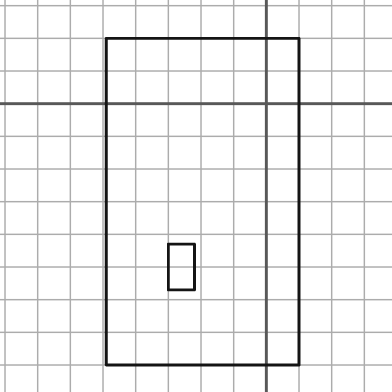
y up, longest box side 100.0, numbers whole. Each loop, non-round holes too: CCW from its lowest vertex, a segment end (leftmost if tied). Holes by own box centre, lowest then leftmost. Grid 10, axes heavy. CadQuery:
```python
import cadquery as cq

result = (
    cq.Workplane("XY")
    .moveTo(-49.0, -80.0)
    .lineTo(10.0, -80.0)
    .lineTo(10.0, 20.0)
    .lineTo(-49.0, 20.0)
    .close()
    .moveTo(-30.0, -57.0)
    .lineTo(-22.0, -57.0)
    .lineTo(-22.0, -43.0)
    .lineTo(-30.0, -43.0)
    .close()
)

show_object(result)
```